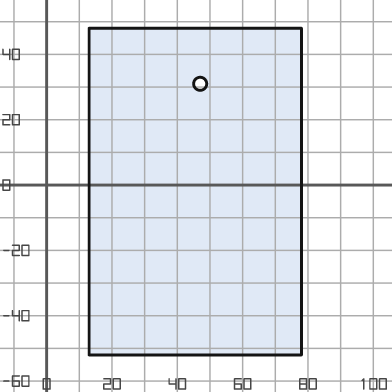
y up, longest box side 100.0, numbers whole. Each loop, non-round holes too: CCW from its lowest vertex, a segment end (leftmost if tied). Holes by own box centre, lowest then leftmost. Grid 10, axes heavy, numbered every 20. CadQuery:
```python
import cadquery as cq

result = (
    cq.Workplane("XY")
    .moveTo(13.0, -52.0)
    .lineTo(78.0, -52.0)
    .lineTo(78.0, 48.0)
    .lineTo(13.0, 48.0)
    .close()
    .moveTo(47.0, 31.0)
    .circle(2.0)
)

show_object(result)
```